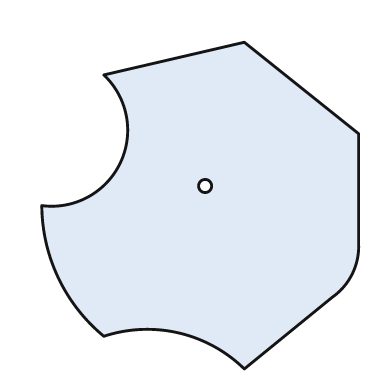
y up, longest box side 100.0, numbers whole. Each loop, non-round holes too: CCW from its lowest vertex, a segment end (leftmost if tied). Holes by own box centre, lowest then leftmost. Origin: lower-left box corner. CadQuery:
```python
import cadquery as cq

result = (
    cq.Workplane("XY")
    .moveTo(62.0, 0.0)
    .lineTo(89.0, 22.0)
    .threePointArc((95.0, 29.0), (97.0, 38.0))
    .lineTo(97.0, 72.0)
    .lineTo(62.0, 100.0)
    .lineTo(19.0, 90.0)
    .threePointArc((24.0, 63.0), (0.0, 50.0))
    .threePointArc((5.0, 28.0), (19.0, 10.0))
    .threePointArc((42.0, 11.0), (62.0, 0.0))
    .close()
    .moveTo(50.0, 56.0)
    .circle(2.0)
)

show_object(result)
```